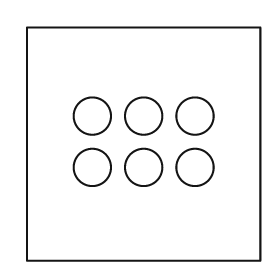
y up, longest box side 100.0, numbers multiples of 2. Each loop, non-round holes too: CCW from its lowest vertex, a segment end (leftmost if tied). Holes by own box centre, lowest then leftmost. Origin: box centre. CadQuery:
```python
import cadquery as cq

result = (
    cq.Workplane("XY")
    .moveTo(-50.0, -50.0)
    .lineTo(50.0, -50.0)
    .lineTo(50.0, 50.0)
    .lineTo(-50.0, 50.0)
    .close()
    .moveTo(-22.0, -10.0)
    .circle(8.0)
    .moveTo(0.0, -10.0)
    .circle(8.0)
    .moveTo(22.0, -10.0)
    .circle(8.0)
    .moveTo(-22.0, 12.0)
    .circle(8.0)
    .moveTo(0.0, 12.0)
    .circle(8.0)
    .moveTo(22.0, 12.0)
    .circle(8.0)
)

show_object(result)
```